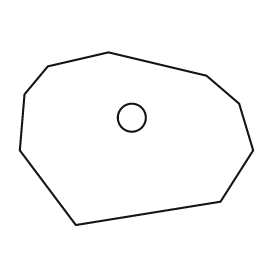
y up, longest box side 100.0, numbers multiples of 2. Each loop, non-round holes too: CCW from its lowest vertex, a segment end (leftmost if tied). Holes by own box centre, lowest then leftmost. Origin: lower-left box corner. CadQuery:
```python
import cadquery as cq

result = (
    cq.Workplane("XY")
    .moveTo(24.0, 0.0)
    .lineTo(86.0, 10.0)
    .lineTo(100.0, 32.0)
    .lineTo(94.0, 52.0)
    .lineTo(80.0, 64.0)
    .lineTo(38.0, 74.0)
    .lineTo(12.0, 68.0)
    .lineTo(2.0, 56.0)
    .lineTo(0.0, 32.0)
    .close()
    .moveTo(48.0, 46.0)
    .circle(6.0)
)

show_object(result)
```